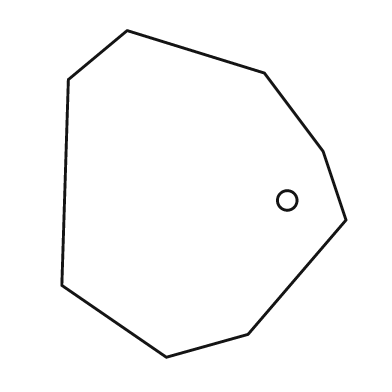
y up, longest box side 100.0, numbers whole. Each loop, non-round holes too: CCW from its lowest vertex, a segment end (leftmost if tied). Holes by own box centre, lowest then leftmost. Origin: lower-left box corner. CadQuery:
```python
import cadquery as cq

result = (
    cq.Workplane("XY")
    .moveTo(32.0, 0.0)
    .lineTo(57.0, 7.0)
    .lineTo(87.0, 42.0)
    .lineTo(80.0, 63.0)
    .lineTo(62.0, 87.0)
    .lineTo(20.0, 100.0)
    .lineTo(2.0, 85.0)
    .lineTo(0.0, 22.0)
    .close()
    .moveTo(69.0, 48.0)
    .circle(3.0)
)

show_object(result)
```